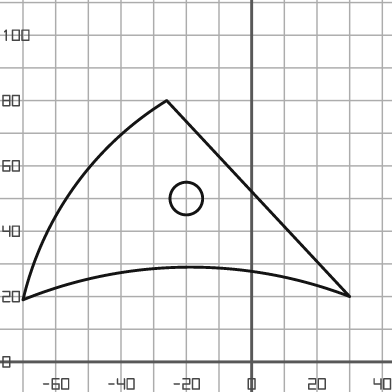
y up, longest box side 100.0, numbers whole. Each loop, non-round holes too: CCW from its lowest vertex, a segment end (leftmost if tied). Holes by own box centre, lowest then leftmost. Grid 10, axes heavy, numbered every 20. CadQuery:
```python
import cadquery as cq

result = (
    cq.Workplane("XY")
    .moveTo(-70.0, 19.0)
    .threePointArc((-20.0, 29.0), (30.0, 20.0))
    .lineTo(-26.0, 80.0)
    .threePointArc((-54.0, 54.0), (-70.0, 19.0))
    .close()
    .moveTo(-20.0, 50.0)
    .circle(5.0)
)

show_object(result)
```